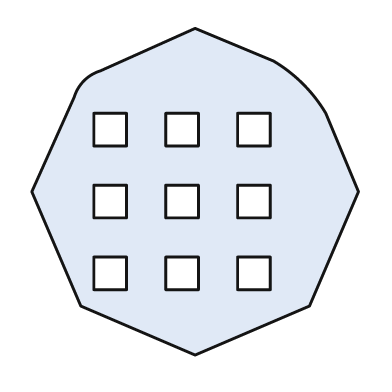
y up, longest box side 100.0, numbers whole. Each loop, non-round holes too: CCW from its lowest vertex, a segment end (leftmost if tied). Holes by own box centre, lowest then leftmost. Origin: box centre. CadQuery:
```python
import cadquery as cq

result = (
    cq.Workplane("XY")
    .moveTo(0.0, -50.0)
    .lineTo(35.0, -35.0)
    .lineTo(50.0, 0.0)
    .lineTo(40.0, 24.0)
    .threePointArc((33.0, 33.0), (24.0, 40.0))
    .lineTo(0.0, 50.0)
    .lineTo(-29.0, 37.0)
    .threePointArc((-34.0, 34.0), (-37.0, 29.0))
    .lineTo(-50.0, 0.0)
    .lineTo(-35.0, -35.0)
    .close()
    .moveTo(-31.0, -30.0)
    .lineTo(-21.0, -30.0)
    .lineTo(-21.0, -20.0)
    .lineTo(-31.0, -20.0)
    .close()
    .moveTo(-9.0, -30.0)
    .lineTo(1.0, -30.0)
    .lineTo(1.0, -20.0)
    .lineTo(-9.0, -20.0)
    .close()
    .moveTo(13.0, -30.0)
    .lineTo(23.0, -30.0)
    .lineTo(23.0, -20.0)
    .lineTo(13.0, -20.0)
    .close()
    .moveTo(-31.0, -8.0)
    .lineTo(-21.0, -8.0)
    .lineTo(-21.0, 2.0)
    .lineTo(-31.0, 2.0)
    .close()
    .moveTo(-9.0, -8.0)
    .lineTo(1.0, -8.0)
    .lineTo(1.0, 2.0)
    .lineTo(-9.0, 2.0)
    .close()
    .moveTo(13.0, -8.0)
    .lineTo(23.0, -8.0)
    .lineTo(23.0, 2.0)
    .lineTo(13.0, 2.0)
    .close()
    .moveTo(-31.0, 14.0)
    .lineTo(-21.0, 14.0)
    .lineTo(-21.0, 24.0)
    .lineTo(-31.0, 24.0)
    .close()
    .moveTo(-9.0, 14.0)
    .lineTo(1.0, 14.0)
    .lineTo(1.0, 24.0)
    .lineTo(-9.0, 24.0)
    .close()
    .moveTo(13.0, 14.0)
    .lineTo(23.0, 14.0)
    .lineTo(23.0, 24.0)
    .lineTo(13.0, 24.0)
    .close()
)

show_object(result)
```